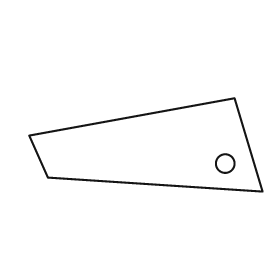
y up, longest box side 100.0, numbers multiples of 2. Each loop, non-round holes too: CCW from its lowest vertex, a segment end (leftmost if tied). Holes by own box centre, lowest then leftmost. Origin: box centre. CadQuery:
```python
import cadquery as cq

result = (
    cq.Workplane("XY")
    .moveTo(50.0, -20.0)
    .lineTo(38.0, 20.0)
    .lineTo(-50.0, 4.0)
    .lineTo(-42.0, -14.0)
    .close()
    .moveTo(34.0, -8.0)
    .circle(4.0)
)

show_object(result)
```